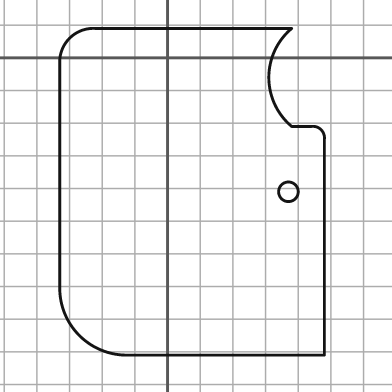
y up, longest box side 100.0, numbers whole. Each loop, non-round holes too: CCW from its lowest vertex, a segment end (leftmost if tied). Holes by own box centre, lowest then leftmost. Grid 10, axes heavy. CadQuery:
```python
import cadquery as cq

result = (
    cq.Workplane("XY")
    .moveTo(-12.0, -91.0)
    .lineTo(48.0, -91.0)
    .lineTo(48.0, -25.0)
    .threePointArc((47.0, -22.0), (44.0, -21.0))
    .lineTo(38.0, -21.0)
    .threePointArc((31.0, -6.0), (38.0, 9.0))
    .lineTo(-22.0, 9.0)
    .threePointArc((-30.0, 6.0), (-33.0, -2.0))
    .lineTo(-33.0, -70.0)
    .threePointArc((-27.0, -85.0), (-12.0, -91.0))
    .close()
    .moveTo(37.0, -41.0)
    .circle(3.0)
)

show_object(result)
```